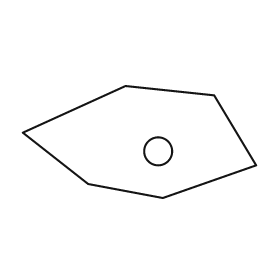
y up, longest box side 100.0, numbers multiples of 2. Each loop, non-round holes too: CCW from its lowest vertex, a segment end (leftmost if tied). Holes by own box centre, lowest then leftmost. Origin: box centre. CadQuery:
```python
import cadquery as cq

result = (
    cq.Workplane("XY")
    .moveTo(10.0, -24.0)
    .lineTo(50.0, -10.0)
    .lineTo(32.0, 20.0)
    .lineTo(-6.0, 24.0)
    .lineTo(-50.0, 4.0)
    .lineTo(-22.0, -18.0)
    .close()
    .moveTo(8.0, -4.0)
    .circle(6.0)
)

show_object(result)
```